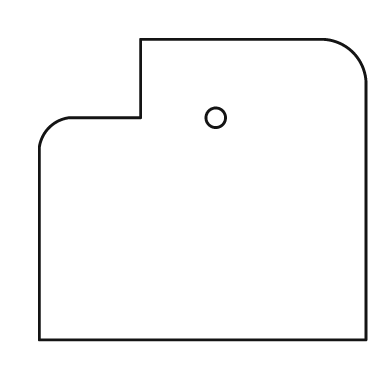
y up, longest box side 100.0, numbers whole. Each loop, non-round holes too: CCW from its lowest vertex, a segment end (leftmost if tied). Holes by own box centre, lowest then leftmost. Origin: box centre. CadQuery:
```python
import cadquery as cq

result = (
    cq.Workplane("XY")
    .moveTo(-50.0, -46.0)
    .lineTo(50.0, -46.0)
    .lineTo(50.0, 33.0)
    .threePointArc((46.0, 42.0), (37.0, 46.0))
    .lineTo(-19.0, 46.0)
    .lineTo(-19.0, 22.0)
    .lineTo(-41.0, 22.0)
    .threePointArc((-47.0, 19.0), (-50.0, 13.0))
    .close()
    .moveTo(4.0, 22.0)
    .circle(3.0)
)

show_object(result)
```